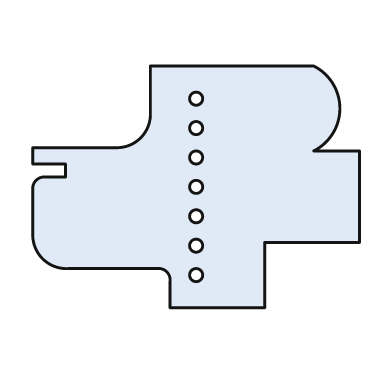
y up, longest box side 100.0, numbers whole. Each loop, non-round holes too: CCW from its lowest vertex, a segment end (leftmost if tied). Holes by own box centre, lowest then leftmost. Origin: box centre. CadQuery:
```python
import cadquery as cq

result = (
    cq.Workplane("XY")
    .moveTo(-8.0, -37.0)
    .lineTo(21.0, -37.0)
    .lineTo(21.0, -17.0)
    .lineTo(50.0, -17.0)
    .lineTo(50.0, 11.0)
    .lineTo(36.0, 11.0)
    .threePointArc((44.0, 24.0), (36.0, 37.0))
    .lineTo(-14.0, 37.0)
    .lineTo(-14.0, 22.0)
    .threePointArc((-17.0, 15.0), (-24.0, 12.0))
    .lineTo(-50.0, 12.0)
    .lineTo(-50.0, 7.0)
    .lineTo(-40.0, 7.0)
    .lineTo(-40.0, 3.0)
    .lineTo(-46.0, 3.0)
    .threePointArc((-49.0, 2.0), (-50.0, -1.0))
    .lineTo(-50.0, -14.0)
    .threePointArc((-47.0, -22.0), (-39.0, -25.0))
    .lineTo(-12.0, -25.0)
    .threePointArc((-9.0, -26.0), (-8.0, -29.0))
    .close()
    .moveTo(0.0, -27.0)
    .circle(2.0)
    .moveTo(0.0, -18.0)
    .circle(2.0)
    .moveTo(0.0, -9.0)
    .circle(2.0)
    .moveTo(0.0, 0.0)
    .circle(2.0)
    .moveTo(0.0, 9.0)
    .circle(2.0)
    .moveTo(0.0, 18.0)
    .circle(2.0)
    .moveTo(0.0, 27.0)
    .circle(2.0)
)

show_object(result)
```